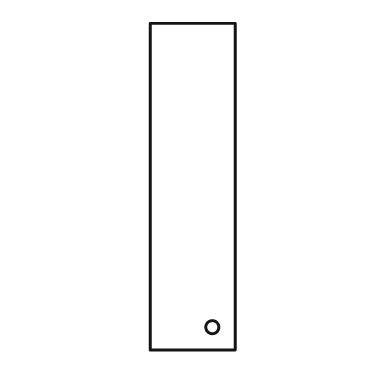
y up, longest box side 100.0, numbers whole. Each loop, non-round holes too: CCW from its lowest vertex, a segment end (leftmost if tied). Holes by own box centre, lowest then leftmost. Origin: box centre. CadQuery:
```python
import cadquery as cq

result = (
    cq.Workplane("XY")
    .moveTo(-13.0, -50.0)
    .lineTo(13.0, -50.0)
    .lineTo(13.0, 50.0)
    .lineTo(-13.0, 50.0)
    .close()
    .moveTo(6.0, -43.0)
    .circle(2.0)
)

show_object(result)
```